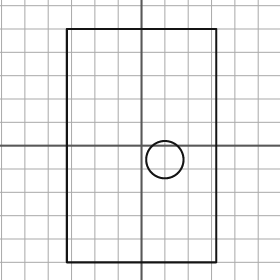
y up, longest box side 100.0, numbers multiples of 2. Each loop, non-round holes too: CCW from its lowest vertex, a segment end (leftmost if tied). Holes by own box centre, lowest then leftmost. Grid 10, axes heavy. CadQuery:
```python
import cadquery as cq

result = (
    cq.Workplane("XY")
    .moveTo(-32.0, -50.0)
    .lineTo(32.0, -50.0)
    .lineTo(32.0, 50.0)
    .lineTo(-32.0, 50.0)
    .close()
    .moveTo(10.0, -6.0)
    .circle(8.0)
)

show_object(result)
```